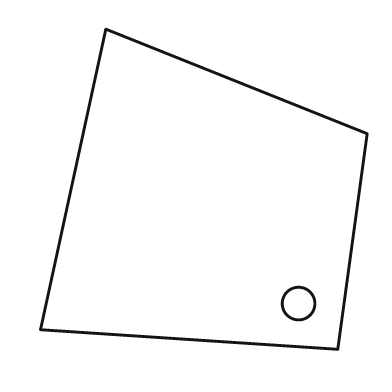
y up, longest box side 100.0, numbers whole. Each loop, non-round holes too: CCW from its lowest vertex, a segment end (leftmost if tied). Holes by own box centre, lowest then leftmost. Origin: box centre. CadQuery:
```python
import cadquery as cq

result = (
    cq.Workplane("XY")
    .moveTo(41.0, -49.0)
    .lineTo(50.0, 17.0)
    .lineTo(-30.0, 49.0)
    .lineTo(-50.0, -43.0)
    .close()
    .moveTo(29.0, -35.0)
    .circle(5.0)
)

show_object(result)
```